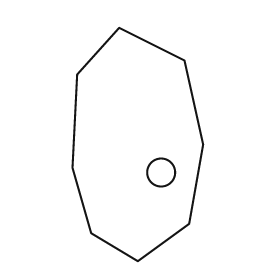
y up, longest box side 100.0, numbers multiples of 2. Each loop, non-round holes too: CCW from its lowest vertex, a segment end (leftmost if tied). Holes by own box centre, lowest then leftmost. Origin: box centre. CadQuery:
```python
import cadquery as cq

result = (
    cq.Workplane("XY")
    .moveTo(0.0, -50.0)
    .lineTo(22.0, -34.0)
    .lineTo(28.0, 0.0)
    .lineTo(20.0, 36.0)
    .lineTo(-8.0, 50.0)
    .lineTo(-26.0, 30.0)
    .lineTo(-28.0, -10.0)
    .lineTo(-20.0, -38.0)
    .close()
    .moveTo(10.0, -12.0)
    .circle(6.0)
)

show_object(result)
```